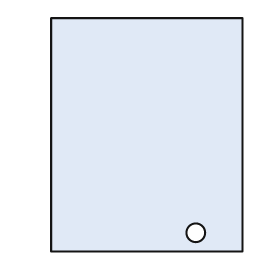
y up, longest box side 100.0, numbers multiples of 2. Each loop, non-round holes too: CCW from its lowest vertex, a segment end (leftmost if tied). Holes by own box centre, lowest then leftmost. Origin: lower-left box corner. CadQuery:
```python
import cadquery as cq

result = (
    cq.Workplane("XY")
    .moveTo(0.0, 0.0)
    .lineTo(82.0, 0.0)
    .lineTo(82.0, 100.0)
    .lineTo(0.0, 100.0)
    .close()
    .moveTo(62.0, 8.0)
    .circle(4.0)
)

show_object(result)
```